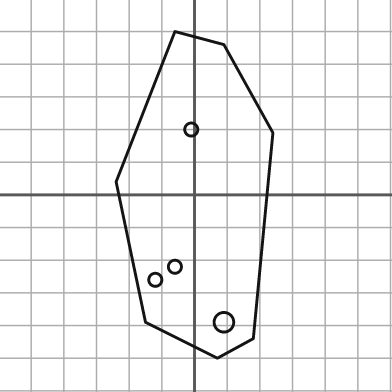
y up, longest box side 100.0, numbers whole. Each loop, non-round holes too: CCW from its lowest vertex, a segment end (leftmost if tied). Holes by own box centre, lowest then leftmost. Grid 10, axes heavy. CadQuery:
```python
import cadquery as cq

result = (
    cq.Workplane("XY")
    .moveTo(7.0, -50.0)
    .lineTo(18.0, -44.0)
    .lineTo(24.0, 19.0)
    .lineTo(9.0, 46.0)
    .lineTo(-6.0, 50.0)
    .lineTo(-24.0, 4.0)
    .lineTo(-15.0, -39.0)
    .close()
    .moveTo(9.0, -39.0)
    .circle(3.0)
    .moveTo(-12.0, -26.0)
    .circle(2.0)
    .moveTo(-6.0, -22.0)
    .circle(2.0)
    .moveTo(-1.0, 20.0)
    .circle(2.0)
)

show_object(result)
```